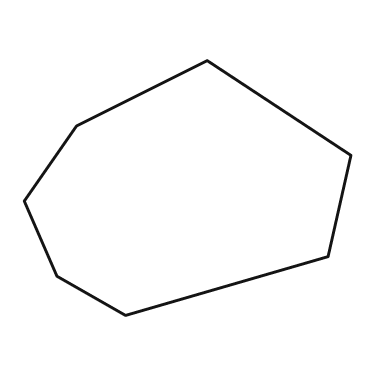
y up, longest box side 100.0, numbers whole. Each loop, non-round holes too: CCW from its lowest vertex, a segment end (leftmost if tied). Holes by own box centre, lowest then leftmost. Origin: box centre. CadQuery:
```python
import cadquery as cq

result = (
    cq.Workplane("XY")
    .moveTo(-19.0, -39.0)
    .lineTo(43.0, -21.0)
    .lineTo(50.0, 10.0)
    .lineTo(6.0, 39.0)
    .lineTo(-34.0, 19.0)
    .lineTo(-50.0, -4.0)
    .lineTo(-40.0, -27.0)
    .close()
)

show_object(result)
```